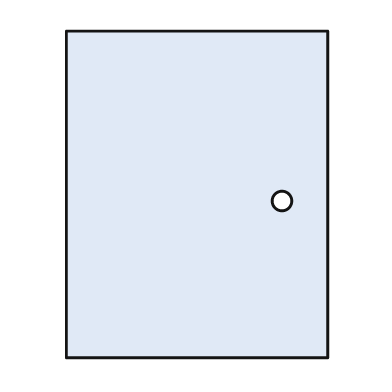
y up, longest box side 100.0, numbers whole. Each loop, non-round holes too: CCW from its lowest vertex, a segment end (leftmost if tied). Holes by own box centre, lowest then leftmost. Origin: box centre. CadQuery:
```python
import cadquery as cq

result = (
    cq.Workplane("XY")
    .moveTo(-40.0, -50.0)
    .lineTo(40.0, -50.0)
    .lineTo(40.0, 50.0)
    .lineTo(-40.0, 50.0)
    .close()
    .moveTo(26.0, -2.0)
    .circle(3.0)
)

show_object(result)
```